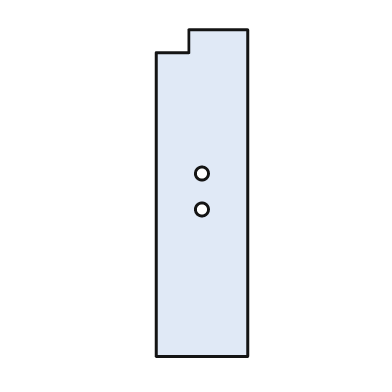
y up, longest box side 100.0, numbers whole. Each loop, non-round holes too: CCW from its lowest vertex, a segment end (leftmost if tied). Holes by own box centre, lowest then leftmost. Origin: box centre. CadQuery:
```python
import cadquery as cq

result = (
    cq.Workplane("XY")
    .moveTo(-14.0, -50.0)
    .lineTo(14.0, -50.0)
    .lineTo(14.0, 50.0)
    .lineTo(-4.0, 50.0)
    .lineTo(-4.0, 43.0)
    .lineTo(-14.0, 43.0)
    .close()
    .moveTo(0.0, -5.0)
    .circle(2.0)
    .moveTo(0.0, 6.0)
    .circle(2.0)
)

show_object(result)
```